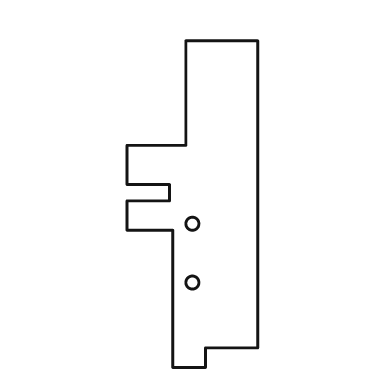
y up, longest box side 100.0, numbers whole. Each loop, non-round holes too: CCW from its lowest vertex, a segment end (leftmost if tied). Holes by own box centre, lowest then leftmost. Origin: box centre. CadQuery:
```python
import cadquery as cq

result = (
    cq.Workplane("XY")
    .moveTo(-6.0, -50.0)
    .lineTo(4.0, -50.0)
    .lineTo(4.0, -44.0)
    .lineTo(20.0, -44.0)
    .lineTo(20.0, 50.0)
    .lineTo(-2.0, 50.0)
    .lineTo(-2.0, 18.0)
    .lineTo(-20.0, 18.0)
    .lineTo(-20.0, 6.0)
    .lineTo(-7.0, 6.0)
    .lineTo(-7.0, 1.0)
    .lineTo(-20.0, 1.0)
    .lineTo(-20.0, -8.0)
    .lineTo(-6.0, -8.0)
    .close()
    .moveTo(0.0, -24.0)
    .circle(2.0)
    .moveTo(0.0, -6.0)
    .circle(2.0)
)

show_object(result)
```